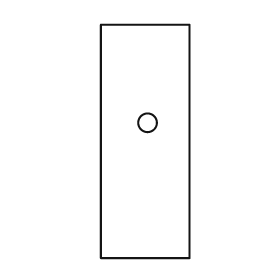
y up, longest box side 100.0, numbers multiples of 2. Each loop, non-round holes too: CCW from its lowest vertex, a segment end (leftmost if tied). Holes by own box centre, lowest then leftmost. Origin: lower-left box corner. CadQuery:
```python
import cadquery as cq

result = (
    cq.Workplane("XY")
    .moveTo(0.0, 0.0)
    .lineTo(38.0, 0.0)
    .lineTo(38.0, 100.0)
    .lineTo(0.0, 100.0)
    .close()
    .moveTo(20.0, 58.0)
    .circle(4.0)
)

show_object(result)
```